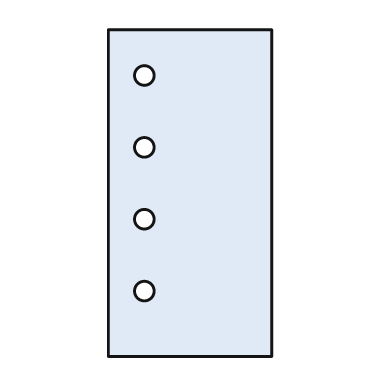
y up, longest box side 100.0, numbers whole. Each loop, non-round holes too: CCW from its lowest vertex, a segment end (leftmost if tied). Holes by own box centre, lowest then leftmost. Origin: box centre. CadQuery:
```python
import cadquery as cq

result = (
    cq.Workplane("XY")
    .moveTo(-25.0, -50.0)
    .lineTo(25.0, -50.0)
    .lineTo(25.0, 50.0)
    .lineTo(-25.0, 50.0)
    .close()
    .moveTo(-14.0, -30.0)
    .circle(3.0)
    .moveTo(-14.0, -8.0)
    .circle(3.0)
    .moveTo(-14.0, 14.0)
    .circle(3.0)
    .moveTo(-14.0, 36.0)
    .circle(3.0)
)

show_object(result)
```